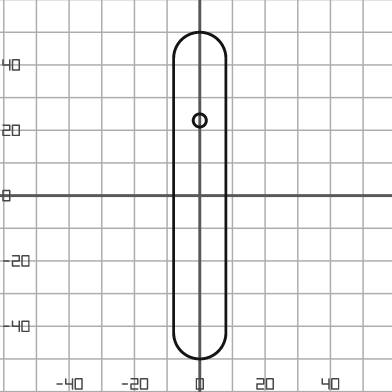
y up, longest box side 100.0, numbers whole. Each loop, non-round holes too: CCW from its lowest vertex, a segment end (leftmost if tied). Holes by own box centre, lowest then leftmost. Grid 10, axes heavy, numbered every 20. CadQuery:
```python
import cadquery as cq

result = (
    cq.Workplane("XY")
    .moveTo(-8.0, -42.0)
    .threePointArc((0.0, -50.0), (8.0, -42.0))
    .lineTo(8.0, 42.0)
    .threePointArc((0.0, 50.0), (-8.0, 42.0))
    .close()
    .moveTo(0.0, 23.0)
    .circle(2.0)
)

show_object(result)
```